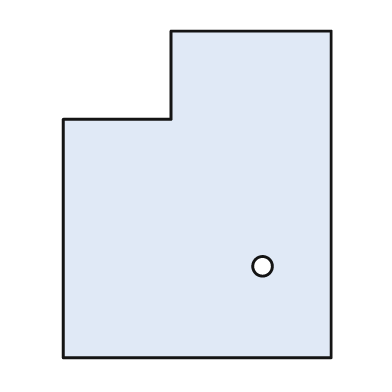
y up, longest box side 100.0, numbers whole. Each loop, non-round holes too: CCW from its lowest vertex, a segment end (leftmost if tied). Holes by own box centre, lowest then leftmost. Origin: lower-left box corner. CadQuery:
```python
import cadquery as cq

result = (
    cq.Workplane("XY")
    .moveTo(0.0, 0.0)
    .lineTo(82.0, 0.0)
    .lineTo(82.0, 100.0)
    .lineTo(33.0, 100.0)
    .lineTo(33.0, 73.0)
    .lineTo(0.0, 73.0)
    .close()
    .moveTo(61.0, 28.0)
    .circle(3.0)
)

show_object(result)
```